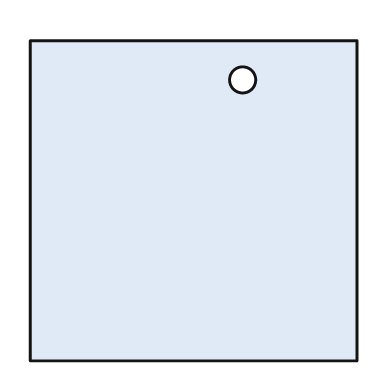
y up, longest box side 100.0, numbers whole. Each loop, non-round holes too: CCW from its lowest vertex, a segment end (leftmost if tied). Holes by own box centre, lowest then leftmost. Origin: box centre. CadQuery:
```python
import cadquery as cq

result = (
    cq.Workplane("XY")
    .moveTo(-50.0, -49.0)
    .lineTo(50.0, -49.0)
    .lineTo(50.0, 49.0)
    .lineTo(-50.0, 49.0)
    .close()
    .moveTo(15.0, 37.0)
    .circle(4.0)
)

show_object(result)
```